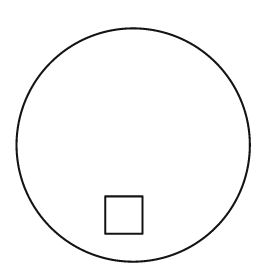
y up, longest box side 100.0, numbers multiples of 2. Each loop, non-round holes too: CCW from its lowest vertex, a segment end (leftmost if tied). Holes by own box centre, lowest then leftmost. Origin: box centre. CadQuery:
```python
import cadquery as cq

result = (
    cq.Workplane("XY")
    .moveTo(0.0, 0.0)
    .circle(50.0)
    .moveTo(-12.0, -38.0)
    .lineTo(4.0, -38.0)
    .lineTo(4.0, -22.0)
    .lineTo(-12.0, -22.0)
    .close()
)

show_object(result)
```